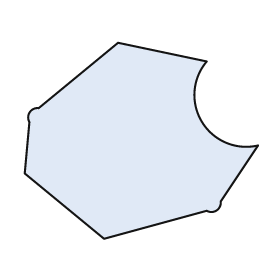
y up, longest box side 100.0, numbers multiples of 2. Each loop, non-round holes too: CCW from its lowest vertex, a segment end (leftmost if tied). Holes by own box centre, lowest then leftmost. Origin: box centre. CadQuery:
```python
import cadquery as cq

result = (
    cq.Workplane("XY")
    .moveTo(-16.0, -42.0)
    .lineTo(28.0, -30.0)
    .threePointArc((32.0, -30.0), (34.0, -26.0))
    .lineTo(50.0, -2.0)
    .threePointArc((26.0, 8.0), (28.0, 34.0))
    .lineTo(-10.0, 42.0)
    .lineTo(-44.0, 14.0)
    .threePointArc((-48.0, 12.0), (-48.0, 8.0))
    .lineTo(-50.0, -14.0)
    .close()
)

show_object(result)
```